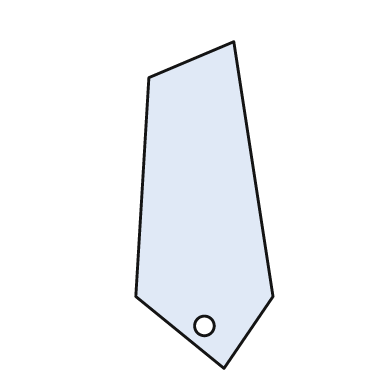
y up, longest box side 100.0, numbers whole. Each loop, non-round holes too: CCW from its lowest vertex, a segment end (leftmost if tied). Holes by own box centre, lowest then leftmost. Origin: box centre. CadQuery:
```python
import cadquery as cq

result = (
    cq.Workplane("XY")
    .moveTo(6.0, -50.0)
    .lineTo(21.0, -28.0)
    .lineTo(9.0, 50.0)
    .lineTo(-17.0, 39.0)
    .lineTo(-21.0, -28.0)
    .close()
    .moveTo(0.0, -37.0)
    .circle(3.0)
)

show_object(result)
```